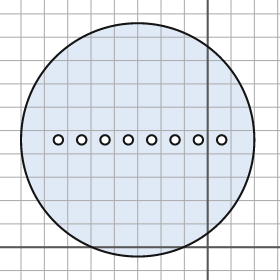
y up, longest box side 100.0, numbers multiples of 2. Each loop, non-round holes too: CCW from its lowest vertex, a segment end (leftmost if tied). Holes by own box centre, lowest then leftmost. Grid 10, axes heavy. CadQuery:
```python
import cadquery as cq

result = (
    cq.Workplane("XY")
    .moveTo(-30.0, 46.0)
    .circle(50.0)
    .moveTo(-64.0, 46.0)
    .circle(2.0)
    .moveTo(-54.0, 46.0)
    .circle(2.0)
    .moveTo(-44.0, 46.0)
    .circle(2.0)
    .moveTo(-34.0, 46.0)
    .circle(2.0)
    .moveTo(-24.0, 46.0)
    .circle(2.0)
    .moveTo(-14.0, 46.0)
    .circle(2.0)
    .moveTo(-4.0, 46.0)
    .circle(2.0)
    .moveTo(6.0, 46.0)
    .circle(2.0)
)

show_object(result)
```